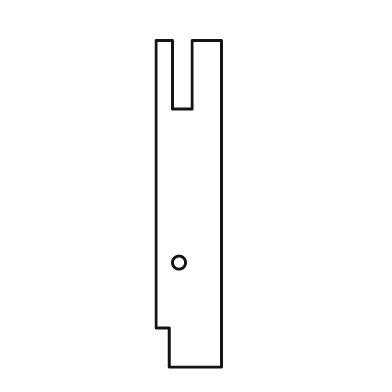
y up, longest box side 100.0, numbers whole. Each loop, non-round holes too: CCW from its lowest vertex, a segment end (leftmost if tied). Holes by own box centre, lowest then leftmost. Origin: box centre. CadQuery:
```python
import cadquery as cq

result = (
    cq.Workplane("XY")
    .moveTo(-6.0, -50.0)
    .lineTo(10.0, -50.0)
    .lineTo(10.0, 50.0)
    .lineTo(1.0, 50.0)
    .lineTo(1.0, 29.0)
    .lineTo(-5.0, 29.0)
    .lineTo(-5.0, 50.0)
    .lineTo(-10.0, 50.0)
    .lineTo(-10.0, -38.0)
    .lineTo(-6.0, -38.0)
    .close()
    .moveTo(-3.0, -18.0)
    .circle(2.0)
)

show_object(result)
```